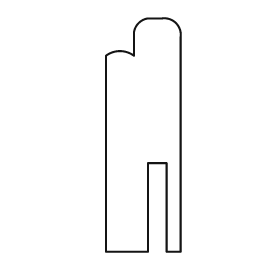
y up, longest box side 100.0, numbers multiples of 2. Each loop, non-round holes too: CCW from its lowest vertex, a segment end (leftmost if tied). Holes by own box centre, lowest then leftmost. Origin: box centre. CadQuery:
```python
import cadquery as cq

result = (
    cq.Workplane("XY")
    .moveTo(-16.0, -50.0)
    .lineTo(2.0, -50.0)
    .lineTo(2.0, -12.0)
    .lineTo(10.0, -12.0)
    .lineTo(10.0, -50.0)
    .lineTo(16.0, -50.0)
    .lineTo(16.0, 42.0)
    .threePointArc((14.0, 48.0), (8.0, 50.0))
    .lineTo(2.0, 50.0)
    .threePointArc((-2.0, 48.0), (-4.0, 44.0))
    .lineTo(-4.0, 34.0)
    .threePointArc((-10.0, 36.0), (-16.0, 34.0))
    .close()
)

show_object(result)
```